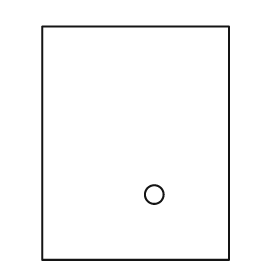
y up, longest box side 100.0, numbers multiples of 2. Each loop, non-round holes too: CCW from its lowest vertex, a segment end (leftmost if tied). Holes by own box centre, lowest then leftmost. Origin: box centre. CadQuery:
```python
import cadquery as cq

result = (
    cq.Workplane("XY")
    .moveTo(-40.0, -50.0)
    .lineTo(40.0, -50.0)
    .lineTo(40.0, 50.0)
    .lineTo(-40.0, 50.0)
    .close()
    .moveTo(8.0, -22.0)
    .circle(4.0)
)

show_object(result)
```